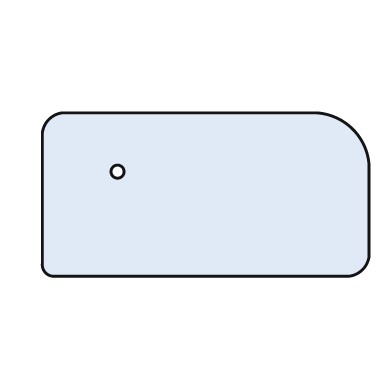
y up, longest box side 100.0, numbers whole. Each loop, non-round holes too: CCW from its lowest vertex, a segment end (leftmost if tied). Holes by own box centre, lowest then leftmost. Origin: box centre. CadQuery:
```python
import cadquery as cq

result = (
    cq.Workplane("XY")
    .moveTo(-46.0, -25.0)
    .lineTo(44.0, -25.0)
    .threePointArc((48.0, -23.0), (50.0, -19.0))
    .lineTo(50.0, 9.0)
    .threePointArc((45.0, 20.0), (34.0, 25.0))
    .lineTo(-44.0, 25.0)
    .threePointArc((-48.0, 23.0), (-50.0, 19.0))
    .lineTo(-50.0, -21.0)
    .threePointArc((-49.0, -24.0), (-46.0, -25.0))
    .close()
    .moveTo(-27.0, 7.0)
    .circle(2.0)
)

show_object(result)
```